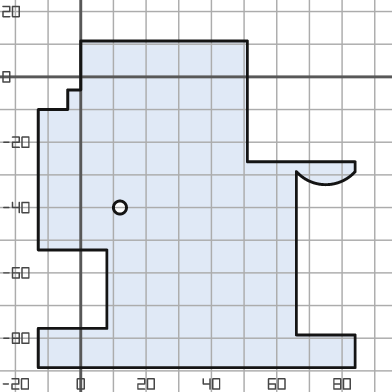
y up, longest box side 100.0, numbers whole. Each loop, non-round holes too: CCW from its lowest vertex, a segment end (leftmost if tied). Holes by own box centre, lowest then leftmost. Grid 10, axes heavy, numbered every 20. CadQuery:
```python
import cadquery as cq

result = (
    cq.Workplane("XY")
    .moveTo(-13.0, -89.0)
    .lineTo(84.0, -89.0)
    .lineTo(84.0, -79.0)
    .lineTo(66.0, -79.0)
    .lineTo(66.0, -29.0)
    .threePointArc((75.0, -33.0), (84.0, -29.0))
    .lineTo(84.0, -26.0)
    .lineTo(51.0, -26.0)
    .lineTo(51.0, 11.0)
    .lineTo(0.0, 11.0)
    .lineTo(0.0, -4.0)
    .lineTo(-4.0, -4.0)
    .lineTo(-4.0, -10.0)
    .lineTo(-13.0, -10.0)
    .lineTo(-13.0, -53.0)
    .lineTo(8.0, -53.0)
    .lineTo(8.0, -77.0)
    .lineTo(-13.0, -77.0)
    .close()
    .moveTo(12.0, -40.0)
    .circle(2.0)
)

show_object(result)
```